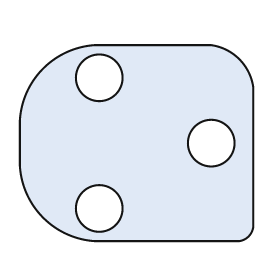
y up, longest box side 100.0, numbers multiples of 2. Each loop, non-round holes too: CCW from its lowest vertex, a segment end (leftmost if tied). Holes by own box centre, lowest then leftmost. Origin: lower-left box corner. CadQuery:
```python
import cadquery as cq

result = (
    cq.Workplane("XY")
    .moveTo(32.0, 0.0)
    .lineTo(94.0, 0.0)
    .threePointArc((98.0, 2.0), (100.0, 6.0))
    .lineTo(100.0, 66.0)
    .threePointArc((94.0, 78.0), (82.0, 84.0))
    .lineTo(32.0, 84.0)
    .threePointArc((10.0, 74.0), (0.0, 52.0))
    .lineTo(0.0, 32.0)
    .threePointArc((10.0, 10.0), (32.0, 0.0))
    .close()
    .moveTo(34.0, 14.0)
    .circle(10.0)
    .moveTo(82.0, 42.0)
    .circle(10.0)
    .moveTo(34.0, 70.0)
    .circle(10.0)
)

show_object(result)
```